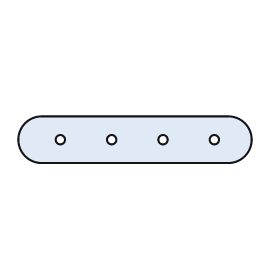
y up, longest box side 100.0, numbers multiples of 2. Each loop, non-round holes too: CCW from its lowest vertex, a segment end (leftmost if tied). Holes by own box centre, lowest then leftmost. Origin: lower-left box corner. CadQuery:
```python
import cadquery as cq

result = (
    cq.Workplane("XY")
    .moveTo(10.0, 0.0)
    .lineTo(90.0, 0.0)
    .threePointArc((100.0, 10.0), (90.0, 20.0))
    .lineTo(10.0, 20.0)
    .threePointArc((0.0, 10.0), (10.0, 0.0))
    .close()
    .moveTo(18.0, 10.0)
    .circle(2.0)
    .moveTo(40.0, 10.0)
    .circle(2.0)
    .moveTo(62.0, 10.0)
    .circle(2.0)
    .moveTo(84.0, 10.0)
    .circle(2.0)
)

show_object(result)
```